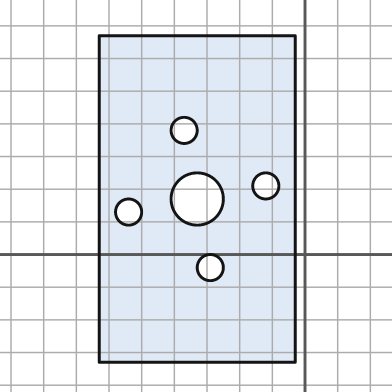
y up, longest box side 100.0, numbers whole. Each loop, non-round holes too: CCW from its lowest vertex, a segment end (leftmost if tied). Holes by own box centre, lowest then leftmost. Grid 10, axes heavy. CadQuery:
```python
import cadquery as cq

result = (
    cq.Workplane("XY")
    .moveTo(-63.0, -33.0)
    .lineTo(-3.0, -33.0)
    .lineTo(-3.0, 67.0)
    .lineTo(-63.0, 67.0)
    .close()
    .moveTo(-29.0, -4.0)
    .circle(4.0)
    .moveTo(-54.0, 13.0)
    .circle(4.0)
    .moveTo(-33.0, 17.0)
    .circle(8.0)
    .moveTo(-12.0, 21.0)
    .circle(4.0)
    .moveTo(-37.0, 38.0)
    .circle(4.0)
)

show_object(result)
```